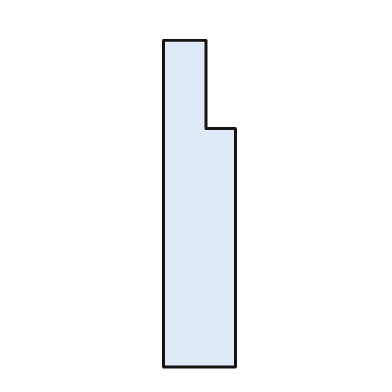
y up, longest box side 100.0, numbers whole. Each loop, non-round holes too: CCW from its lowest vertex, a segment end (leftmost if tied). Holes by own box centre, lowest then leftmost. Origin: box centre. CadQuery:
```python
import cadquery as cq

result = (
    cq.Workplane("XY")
    .moveTo(-11.0, -50.0)
    .lineTo(11.0, -50.0)
    .lineTo(11.0, 23.0)
    .lineTo(2.0, 23.0)
    .lineTo(2.0, 50.0)
    .lineTo(-11.0, 50.0)
    .close()
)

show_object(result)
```